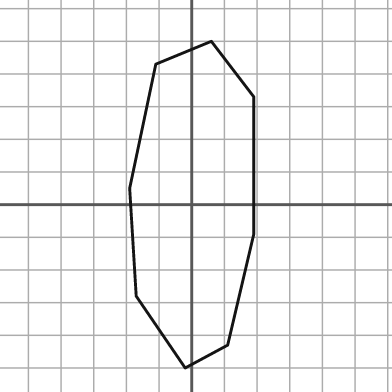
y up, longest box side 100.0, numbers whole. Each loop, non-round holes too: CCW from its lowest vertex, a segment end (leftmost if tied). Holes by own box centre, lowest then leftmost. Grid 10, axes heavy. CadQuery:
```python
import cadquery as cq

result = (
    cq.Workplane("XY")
    .moveTo(-2.0, -50.0)
    .lineTo(11.0, -43.0)
    .lineTo(19.0, -9.0)
    .lineTo(19.0, 33.0)
    .lineTo(6.0, 50.0)
    .lineTo(-11.0, 43.0)
    .lineTo(-19.0, 5.0)
    .lineTo(-17.0, -28.0)
    .close()
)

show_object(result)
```